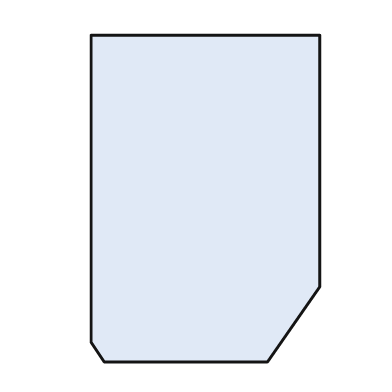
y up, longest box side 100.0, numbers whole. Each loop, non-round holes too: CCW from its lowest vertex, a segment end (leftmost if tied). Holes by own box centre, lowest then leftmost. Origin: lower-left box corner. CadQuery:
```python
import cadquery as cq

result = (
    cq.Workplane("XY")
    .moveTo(4.0, 0.0)
    .lineTo(54.0, 0.0)
    .lineTo(70.0, 23.0)
    .lineTo(70.0, 100.0)
    .lineTo(0.0, 100.0)
    .lineTo(0.0, 6.0)
    .close()
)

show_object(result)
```